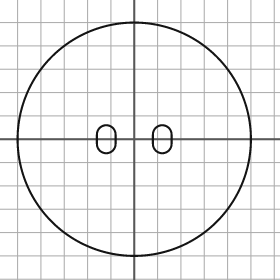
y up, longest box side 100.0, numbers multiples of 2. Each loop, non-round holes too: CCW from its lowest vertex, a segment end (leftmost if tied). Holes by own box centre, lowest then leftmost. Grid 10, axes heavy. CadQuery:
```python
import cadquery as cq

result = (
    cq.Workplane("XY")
    .moveTo(0.0, 0.0)
    .circle(50.0)
    .moveTo(-16.0, -2.0)
    .threePointArc((-12.0, -6.0), (-8.0, -2.0))
    .lineTo(-8.0, 2.0)
    .threePointArc((-12.0, 6.0), (-16.0, 2.0))
    .close()
    .moveTo(8.0, -2.0)
    .threePointArc((12.0, -6.0), (16.0, -2.0))
    .lineTo(16.0, 2.0)
    .threePointArc((12.0, 6.0), (8.0, 2.0))
    .close()
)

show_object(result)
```